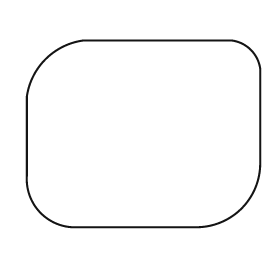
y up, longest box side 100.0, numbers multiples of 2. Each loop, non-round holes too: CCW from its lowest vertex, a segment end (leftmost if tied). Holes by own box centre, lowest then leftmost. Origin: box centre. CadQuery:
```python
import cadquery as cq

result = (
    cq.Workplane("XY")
    .moveTo(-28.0, -40.0)
    .lineTo(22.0, -40.0)
    .threePointArc((42.0, -32.0), (50.0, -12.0))
    .lineTo(50.0, 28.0)
    .threePointArc((46.0, 36.0), (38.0, 40.0))
    .lineTo(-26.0, 40.0)
    .threePointArc((-42.0, 32.0), (-50.0, 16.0))
    .lineTo(-50.0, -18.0)
    .threePointArc((-44.0, -34.0), (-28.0, -40.0))
    .close()
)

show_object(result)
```